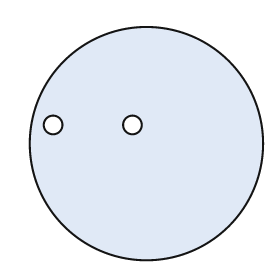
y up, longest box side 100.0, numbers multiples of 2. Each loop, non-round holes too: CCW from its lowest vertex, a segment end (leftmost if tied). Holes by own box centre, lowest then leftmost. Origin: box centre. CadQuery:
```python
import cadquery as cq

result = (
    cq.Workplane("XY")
    .moveTo(0.0, 0.0)
    .circle(50.0)
    .moveTo(-40.0, 8.0)
    .circle(4.0)
    .moveTo(-6.0, 8.0)
    .circle(4.0)
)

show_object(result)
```